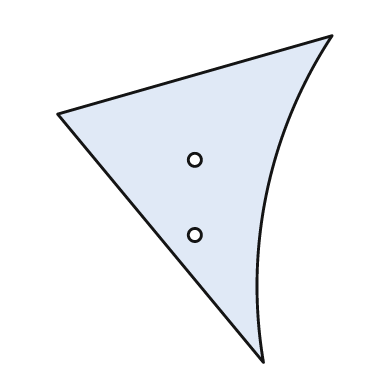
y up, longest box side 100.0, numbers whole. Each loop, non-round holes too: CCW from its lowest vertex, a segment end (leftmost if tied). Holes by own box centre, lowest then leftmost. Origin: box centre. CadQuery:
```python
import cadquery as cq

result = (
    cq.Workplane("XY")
    .moveTo(21.0, -50.0)
    .threePointArc((22.0, 2.0), (42.0, 50.0))
    .lineTo(-42.0, 26.0)
    .close()
    .moveTo(0.0, -11.0)
    .circle(2.0)
    .moveTo(0.0, 12.0)
    .circle(2.0)
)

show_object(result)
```